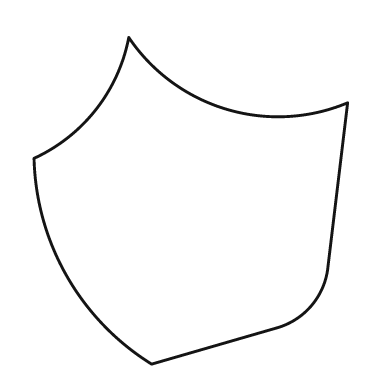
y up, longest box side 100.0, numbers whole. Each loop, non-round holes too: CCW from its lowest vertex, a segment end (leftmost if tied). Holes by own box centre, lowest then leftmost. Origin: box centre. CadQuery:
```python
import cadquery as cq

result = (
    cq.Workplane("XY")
    .moveTo(-12.0, -50.0)
    .lineTo(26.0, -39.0)
    .threePointArc((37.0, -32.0), (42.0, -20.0))
    .lineTo(48.0, 30.0)
    .threePointArc((11.0, 28.0), (-19.0, 50.0))
    .threePointArc((-29.0, 28.0), (-48.0, 13.0))
    .threePointArc((-38.0, -23.0), (-12.0, -50.0))
    .close()
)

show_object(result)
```